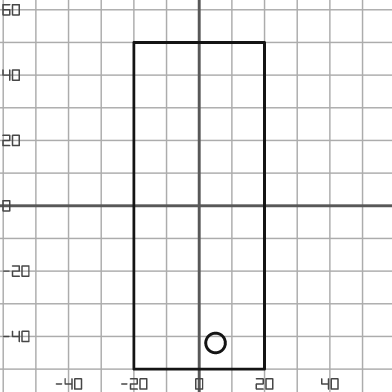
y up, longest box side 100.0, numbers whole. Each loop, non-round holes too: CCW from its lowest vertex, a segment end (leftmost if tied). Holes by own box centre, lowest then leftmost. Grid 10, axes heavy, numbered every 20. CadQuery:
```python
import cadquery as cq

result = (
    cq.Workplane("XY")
    .moveTo(-20.0, -50.0)
    .lineTo(20.0, -50.0)
    .lineTo(20.0, 50.0)
    .lineTo(-20.0, 50.0)
    .close()
    .moveTo(5.0, -42.0)
    .circle(3.0)
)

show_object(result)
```